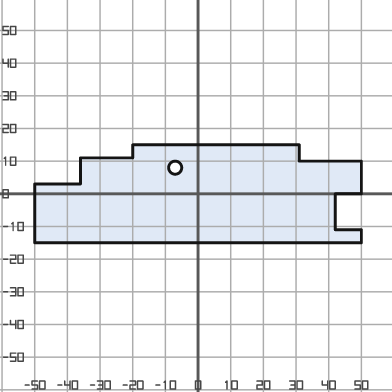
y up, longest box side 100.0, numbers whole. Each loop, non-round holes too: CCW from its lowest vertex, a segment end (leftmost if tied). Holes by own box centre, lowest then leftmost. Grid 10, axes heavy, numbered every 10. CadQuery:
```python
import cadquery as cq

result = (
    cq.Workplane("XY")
    .moveTo(-50.0, -15.0)
    .lineTo(50.0, -15.0)
    .lineTo(50.0, -11.0)
    .lineTo(42.0, -11.0)
    .lineTo(42.0, 0.0)
    .lineTo(50.0, 0.0)
    .lineTo(50.0, 10.0)
    .lineTo(31.0, 10.0)
    .lineTo(31.0, 15.0)
    .lineTo(-20.0, 15.0)
    .lineTo(-20.0, 11.0)
    .lineTo(-36.0, 11.0)
    .lineTo(-36.0, 3.0)
    .lineTo(-50.0, 3.0)
    .close()
    .moveTo(-7.0, 8.0)
    .circle(2.0)
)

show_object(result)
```